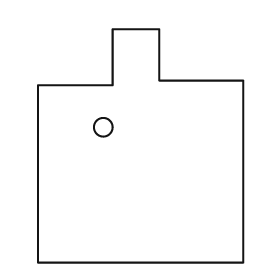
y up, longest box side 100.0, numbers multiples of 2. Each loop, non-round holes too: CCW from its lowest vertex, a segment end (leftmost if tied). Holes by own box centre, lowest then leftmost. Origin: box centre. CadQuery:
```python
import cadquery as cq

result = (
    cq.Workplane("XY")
    .moveTo(-44.0, -50.0)
    .lineTo(44.0, -50.0)
    .lineTo(44.0, 28.0)
    .lineTo(8.0, 28.0)
    .lineTo(8.0, 50.0)
    .lineTo(-12.0, 50.0)
    .lineTo(-12.0, 26.0)
    .lineTo(-44.0, 26.0)
    .close()
    .moveTo(-16.0, 8.0)
    .circle(4.0)
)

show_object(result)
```